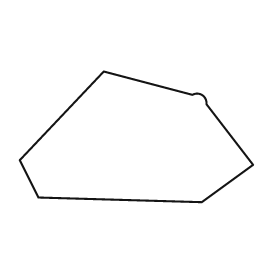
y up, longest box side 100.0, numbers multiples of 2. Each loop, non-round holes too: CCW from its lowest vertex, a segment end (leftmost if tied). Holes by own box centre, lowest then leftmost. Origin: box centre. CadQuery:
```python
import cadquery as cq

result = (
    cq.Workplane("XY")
    .moveTo(28.0, -28.0)
    .lineTo(50.0, -12.0)
    .lineTo(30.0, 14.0)
    .threePointArc((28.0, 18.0), (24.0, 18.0))
    .lineTo(-14.0, 28.0)
    .lineTo(-50.0, -10.0)
    .lineTo(-42.0, -26.0)
    .close()
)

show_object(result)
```